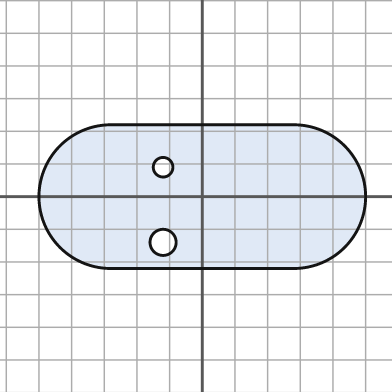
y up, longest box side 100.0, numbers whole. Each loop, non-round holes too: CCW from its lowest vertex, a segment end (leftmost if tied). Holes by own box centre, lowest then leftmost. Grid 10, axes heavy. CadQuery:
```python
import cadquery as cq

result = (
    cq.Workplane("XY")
    .moveTo(-28.0, -22.0)
    .lineTo(28.0, -22.0)
    .threePointArc((50.0, 0.0), (28.0, 22.0))
    .lineTo(-28.0, 22.0)
    .threePointArc((-50.0, 0.0), (-28.0, -22.0))
    .close()
    .moveTo(-12.0, -14.0)
    .circle(4.0)
    .moveTo(-12.0, 9.0)
    .circle(3.0)
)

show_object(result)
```